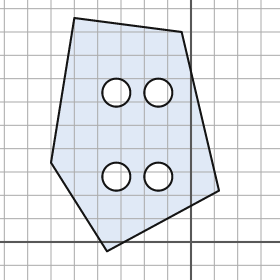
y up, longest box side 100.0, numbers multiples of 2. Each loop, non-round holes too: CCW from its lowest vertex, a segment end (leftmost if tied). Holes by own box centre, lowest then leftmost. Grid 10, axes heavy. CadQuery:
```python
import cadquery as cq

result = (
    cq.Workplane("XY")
    .moveTo(-36.0, -4.0)
    .lineTo(12.0, 22.0)
    .lineTo(-4.0, 90.0)
    .lineTo(-50.0, 96.0)
    .lineTo(-60.0, 34.0)
    .close()
    .moveTo(-32.0, 28.0)
    .circle(6.0)
    .moveTo(-14.0, 28.0)
    .circle(6.0)
    .moveTo(-32.0, 64.0)
    .circle(6.0)
    .moveTo(-14.0, 64.0)
    .circle(6.0)
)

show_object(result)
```